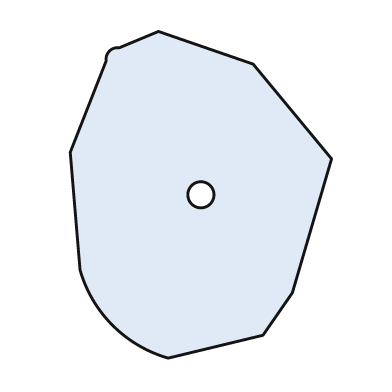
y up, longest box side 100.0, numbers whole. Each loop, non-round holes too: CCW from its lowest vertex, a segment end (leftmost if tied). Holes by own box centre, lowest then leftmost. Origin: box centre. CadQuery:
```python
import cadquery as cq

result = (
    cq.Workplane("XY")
    .moveTo(-10.0, -50.0)
    .lineTo(19.0, -43.0)
    .lineTo(28.0, -30.0)
    .lineTo(40.0, 11.0)
    .lineTo(16.0, 40.0)
    .lineTo(-13.0, 50.0)
    .lineTo(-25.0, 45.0)
    .threePointArc((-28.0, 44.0), (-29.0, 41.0))
    .lineTo(-40.0, 13.0)
    .lineTo(-37.0, -23.0)
    .threePointArc((-27.0, -40.0), (-10.0, -50.0))
    .close()
    .moveTo(0.0, 0.0)
    .circle(4.0)
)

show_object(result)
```